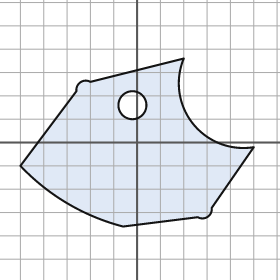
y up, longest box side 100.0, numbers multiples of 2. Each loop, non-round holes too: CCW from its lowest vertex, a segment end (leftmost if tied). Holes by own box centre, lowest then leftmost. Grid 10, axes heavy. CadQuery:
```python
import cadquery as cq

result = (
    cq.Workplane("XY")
    .moveTo(-6.0, -36.0)
    .lineTo(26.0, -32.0)
    .threePointArc((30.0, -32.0), (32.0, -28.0))
    .lineTo(50.0, -2.0)
    .threePointArc((24.0, 8.0), (20.0, 36.0))
    .lineTo(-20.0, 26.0)
    .threePointArc((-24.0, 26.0), (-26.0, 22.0))
    .lineTo(-50.0, -10.0)
    .threePointArc((-30.0, -26.0), (-6.0, -36.0))
    .close()
    .moveTo(-2.0, 16.0)
    .circle(6.0)
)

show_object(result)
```